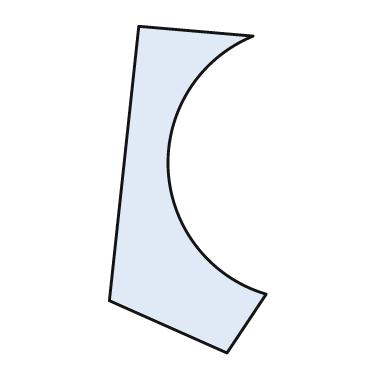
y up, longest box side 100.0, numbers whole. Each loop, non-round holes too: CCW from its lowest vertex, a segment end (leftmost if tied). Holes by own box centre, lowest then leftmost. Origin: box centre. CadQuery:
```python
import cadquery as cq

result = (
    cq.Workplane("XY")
    .moveTo(12.0, -50.0)
    .lineTo(24.0, -32.0)
    .threePointArc((-6.0, 6.0), (20.0, 47.0))
    .lineTo(-15.0, 50.0)
    .lineTo(-24.0, -34.0)
    .close()
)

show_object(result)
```